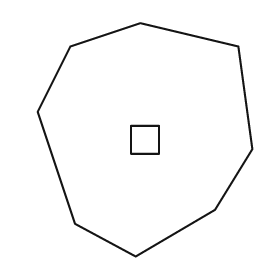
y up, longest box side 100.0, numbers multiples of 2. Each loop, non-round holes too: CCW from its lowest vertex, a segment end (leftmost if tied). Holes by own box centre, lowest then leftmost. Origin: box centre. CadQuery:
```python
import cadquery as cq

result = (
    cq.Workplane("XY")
    .moveTo(-4.0, -50.0)
    .lineTo(30.0, -30.0)
    .lineTo(46.0, -4.0)
    .lineTo(40.0, 40.0)
    .lineTo(-2.0, 50.0)
    .lineTo(-32.0, 40.0)
    .lineTo(-46.0, 12.0)
    .lineTo(-30.0, -36.0)
    .close()
    .moveTo(-6.0, -6.0)
    .lineTo(6.0, -6.0)
    .lineTo(6.0, 6.0)
    .lineTo(-6.0, 6.0)
    .close()
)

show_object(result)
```